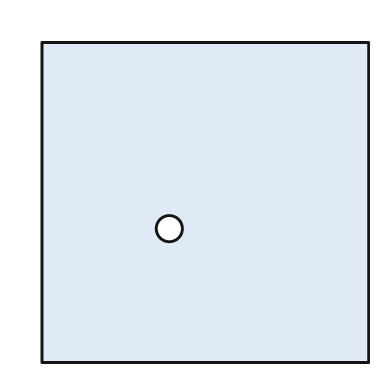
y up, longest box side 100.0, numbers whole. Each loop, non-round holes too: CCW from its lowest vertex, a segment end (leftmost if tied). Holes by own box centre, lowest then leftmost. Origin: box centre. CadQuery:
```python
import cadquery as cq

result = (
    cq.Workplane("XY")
    .moveTo(-50.0, -49.0)
    .lineTo(50.0, -49.0)
    .lineTo(50.0, 49.0)
    .lineTo(-50.0, 49.0)
    .close()
    .moveTo(-11.0, -8.0)
    .circle(4.0)
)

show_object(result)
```